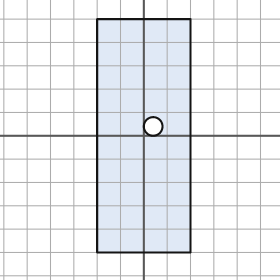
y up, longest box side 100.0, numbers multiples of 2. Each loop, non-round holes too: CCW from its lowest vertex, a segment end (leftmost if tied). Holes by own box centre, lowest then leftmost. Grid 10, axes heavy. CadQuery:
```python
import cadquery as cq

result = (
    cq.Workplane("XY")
    .moveTo(-20.0, -50.0)
    .lineTo(20.0, -50.0)
    .lineTo(20.0, 50.0)
    .lineTo(-20.0, 50.0)
    .close()
    .moveTo(4.0, 4.0)
    .circle(4.0)
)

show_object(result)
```